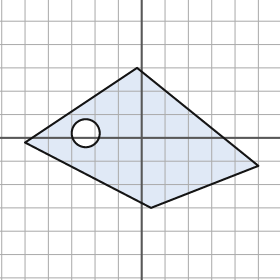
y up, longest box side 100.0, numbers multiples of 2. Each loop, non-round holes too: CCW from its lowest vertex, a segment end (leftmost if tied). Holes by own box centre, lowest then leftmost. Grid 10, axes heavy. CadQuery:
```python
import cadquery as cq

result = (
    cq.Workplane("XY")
    .moveTo(4.0, -30.0)
    .lineTo(50.0, -12.0)
    .lineTo(-2.0, 30.0)
    .lineTo(-50.0, -2.0)
    .close()
    .moveTo(-24.0, 2.0)
    .circle(6.0)
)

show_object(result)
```